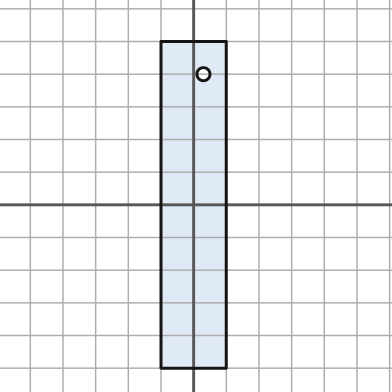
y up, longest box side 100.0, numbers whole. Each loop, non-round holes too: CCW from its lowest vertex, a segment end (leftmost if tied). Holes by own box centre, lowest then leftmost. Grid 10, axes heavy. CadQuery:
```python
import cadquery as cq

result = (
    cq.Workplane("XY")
    .moveTo(-10.0, -50.0)
    .lineTo(10.0, -50.0)
    .lineTo(10.0, 50.0)
    .lineTo(-10.0, 50.0)
    .close()
    .moveTo(3.0, 40.0)
    .circle(2.0)
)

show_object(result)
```